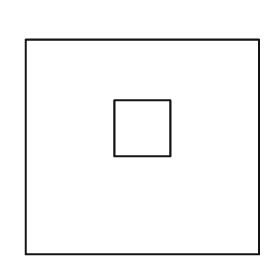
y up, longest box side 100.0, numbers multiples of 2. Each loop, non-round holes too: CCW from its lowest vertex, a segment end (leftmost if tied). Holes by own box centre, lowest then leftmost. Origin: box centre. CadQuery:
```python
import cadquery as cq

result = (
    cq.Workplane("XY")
    .moveTo(-50.0, -46.0)
    .lineTo(50.0, -46.0)
    .lineTo(50.0, 46.0)
    .lineTo(-50.0, 46.0)
    .close()
    .moveTo(-12.0, -4.0)
    .lineTo(12.0, -4.0)
    .lineTo(12.0, 20.0)
    .lineTo(-12.0, 20.0)
    .close()
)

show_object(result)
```